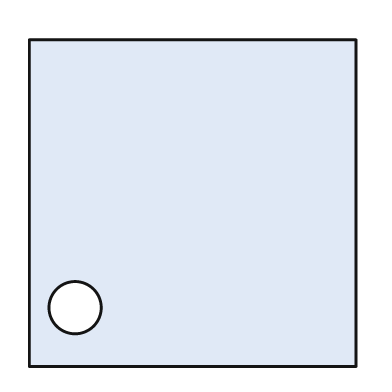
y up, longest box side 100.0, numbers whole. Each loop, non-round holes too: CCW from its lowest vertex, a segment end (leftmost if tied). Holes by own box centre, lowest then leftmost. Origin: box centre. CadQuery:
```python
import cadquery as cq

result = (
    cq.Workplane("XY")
    .moveTo(-50.0, -50.0)
    .lineTo(50.0, -50.0)
    .lineTo(50.0, 50.0)
    .lineTo(-50.0, 50.0)
    .close()
    .moveTo(-36.0, -32.0)
    .circle(8.0)
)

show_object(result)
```